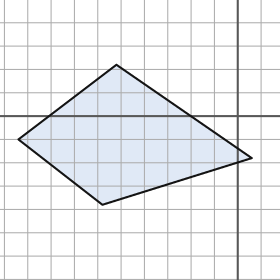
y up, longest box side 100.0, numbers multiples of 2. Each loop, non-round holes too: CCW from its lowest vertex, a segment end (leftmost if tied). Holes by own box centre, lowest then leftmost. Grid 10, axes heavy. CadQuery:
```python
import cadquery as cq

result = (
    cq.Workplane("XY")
    .moveTo(-58.0, -38.0)
    .lineTo(6.0, -18.0)
    .lineTo(-52.0, 22.0)
    .lineTo(-94.0, -10.0)
    .close()
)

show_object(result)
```